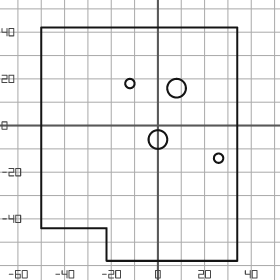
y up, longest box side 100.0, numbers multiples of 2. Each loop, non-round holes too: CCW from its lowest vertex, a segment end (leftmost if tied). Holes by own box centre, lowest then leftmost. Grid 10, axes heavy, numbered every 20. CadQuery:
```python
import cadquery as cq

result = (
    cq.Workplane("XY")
    .moveTo(-22.0, -58.0)
    .lineTo(34.0, -58.0)
    .lineTo(34.0, 42.0)
    .lineTo(-50.0, 42.0)
    .lineTo(-50.0, -44.0)
    .lineTo(-22.0, -44.0)
    .close()
    .moveTo(26.0, -14.0)
    .circle(2.0)
    .moveTo(0.0, -6.0)
    .circle(4.0)
    .moveTo(8.0, 16.0)
    .circle(4.0)
    .moveTo(-12.0, 18.0)
    .circle(2.0)
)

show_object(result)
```